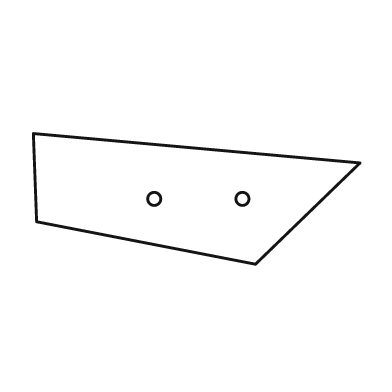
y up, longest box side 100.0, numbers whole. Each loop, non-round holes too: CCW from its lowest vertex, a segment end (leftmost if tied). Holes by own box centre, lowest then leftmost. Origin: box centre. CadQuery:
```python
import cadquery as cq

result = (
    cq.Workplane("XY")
    .moveTo(18.0, -20.0)
    .lineTo(50.0, 11.0)
    .lineTo(-50.0, 20.0)
    .lineTo(-49.0, -7.0)
    .close()
    .moveTo(-13.0, 0.0)
    .circle(2.0)
    .moveTo(14.0, 0.0)
    .circle(2.0)
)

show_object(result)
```